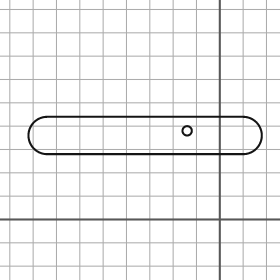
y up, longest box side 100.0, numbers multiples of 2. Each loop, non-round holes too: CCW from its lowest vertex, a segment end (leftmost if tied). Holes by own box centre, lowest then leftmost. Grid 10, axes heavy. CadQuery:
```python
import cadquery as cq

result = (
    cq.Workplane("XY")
    .moveTo(-74.0, 28.0)
    .lineTo(10.0, 28.0)
    .threePointArc((18.0, 36.0), (10.0, 44.0))
    .lineTo(-74.0, 44.0)
    .threePointArc((-82.0, 36.0), (-74.0, 28.0))
    .close()
    .moveTo(-14.0, 38.0)
    .circle(2.0)
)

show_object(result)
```